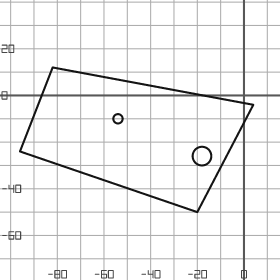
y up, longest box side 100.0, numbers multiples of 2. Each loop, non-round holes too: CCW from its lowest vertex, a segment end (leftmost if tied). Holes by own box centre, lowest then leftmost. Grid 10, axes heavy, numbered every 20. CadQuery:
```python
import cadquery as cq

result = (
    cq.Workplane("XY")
    .moveTo(-20.0, -50.0)
    .lineTo(4.0, -4.0)
    .lineTo(-82.0, 12.0)
    .lineTo(-96.0, -24.0)
    .close()
    .moveTo(-18.0, -26.0)
    .circle(4.0)
    .moveTo(-54.0, -10.0)
    .circle(2.0)
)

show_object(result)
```